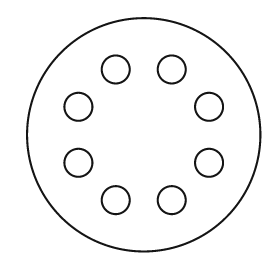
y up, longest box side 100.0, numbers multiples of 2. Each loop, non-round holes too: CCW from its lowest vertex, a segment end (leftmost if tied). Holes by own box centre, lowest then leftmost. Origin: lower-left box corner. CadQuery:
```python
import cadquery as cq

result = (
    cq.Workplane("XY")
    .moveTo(50.0, 50.0)
    .circle(50.0)
    .moveTo(38.0, 22.0)
    .circle(6.0)
    .moveTo(62.0, 22.0)
    .circle(6.0)
    .moveTo(22.0, 38.0)
    .circle(6.0)
    .moveTo(78.0, 38.0)
    .circle(6.0)
    .moveTo(22.0, 62.0)
    .circle(6.0)
    .moveTo(78.0, 62.0)
    .circle(6.0)
    .moveTo(38.0, 78.0)
    .circle(6.0)
    .moveTo(62.0, 78.0)
    .circle(6.0)
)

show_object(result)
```